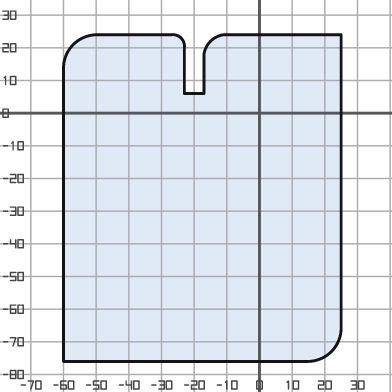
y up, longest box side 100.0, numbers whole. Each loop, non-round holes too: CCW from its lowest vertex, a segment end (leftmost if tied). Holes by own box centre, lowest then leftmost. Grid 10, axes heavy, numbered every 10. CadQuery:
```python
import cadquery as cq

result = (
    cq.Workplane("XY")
    .moveTo(-60.0, -76.0)
    .lineTo(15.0, -76.0)
    .threePointArc((22.0, -73.0), (25.0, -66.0))
    .lineTo(25.0, 24.0)
    .lineTo(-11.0, 24.0)
    .threePointArc((-15.0, 22.0), (-17.0, 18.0))
    .lineTo(-17.0, 6.0)
    .lineTo(-23.0, 6.0)
    .lineTo(-23.0, 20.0)
    .threePointArc((-24.0, 23.0), (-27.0, 24.0))
    .lineTo(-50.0, 24.0)
    .threePointArc((-57.0, 21.0), (-60.0, 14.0))
    .close()
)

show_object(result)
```